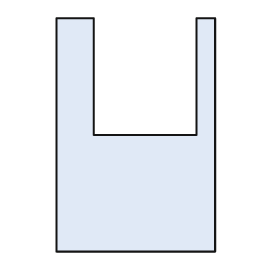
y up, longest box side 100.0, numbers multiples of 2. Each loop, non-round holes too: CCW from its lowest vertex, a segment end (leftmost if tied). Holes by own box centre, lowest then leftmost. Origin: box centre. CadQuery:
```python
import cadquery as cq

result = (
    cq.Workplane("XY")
    .moveTo(-34.0, -50.0)
    .lineTo(34.0, -50.0)
    .lineTo(34.0, 50.0)
    .lineTo(26.0, 50.0)
    .lineTo(26.0, 0.0)
    .lineTo(-18.0, 0.0)
    .lineTo(-18.0, 50.0)
    .lineTo(-34.0, 50.0)
    .close()
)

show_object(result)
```